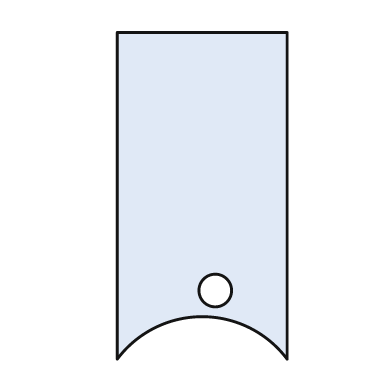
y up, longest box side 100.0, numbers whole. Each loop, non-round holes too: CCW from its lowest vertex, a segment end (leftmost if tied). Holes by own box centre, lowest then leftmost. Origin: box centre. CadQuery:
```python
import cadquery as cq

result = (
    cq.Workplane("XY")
    .moveTo(-26.0, -50.0)
    .threePointArc((0.0, -37.0), (26.0, -50.0))
    .lineTo(26.0, 50.0)
    .lineTo(-26.0, 50.0)
    .close()
    .moveTo(4.0, -29.0)
    .circle(5.0)
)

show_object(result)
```